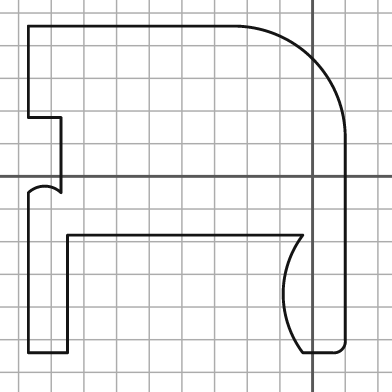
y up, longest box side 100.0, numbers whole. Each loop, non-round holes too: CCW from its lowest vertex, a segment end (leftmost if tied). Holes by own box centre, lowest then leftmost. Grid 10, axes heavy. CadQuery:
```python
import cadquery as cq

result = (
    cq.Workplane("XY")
    .moveTo(-87.0, -54.0)
    .lineTo(-75.0, -54.0)
    .lineTo(-75.0, -18.0)
    .lineTo(-3.0, -18.0)
    .threePointArc((-9.0, -36.0), (-3.0, -54.0))
    .lineTo(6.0, -54.0)
    .threePointArc((9.0, -53.0), (10.0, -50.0))
    .lineTo(10.0, 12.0)
    .threePointArc((0.0, 36.0), (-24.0, 46.0))
    .lineTo(-87.0, 46.0)
    .lineTo(-87.0, 18.0)
    .lineTo(-77.0, 18.0)
    .lineTo(-77.0, -5.0)
    .threePointArc((-82.0, -3.0), (-87.0, -5.0))
    .close()
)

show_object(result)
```